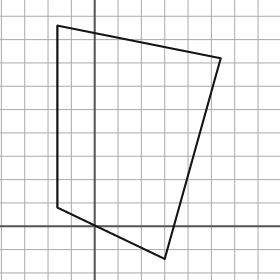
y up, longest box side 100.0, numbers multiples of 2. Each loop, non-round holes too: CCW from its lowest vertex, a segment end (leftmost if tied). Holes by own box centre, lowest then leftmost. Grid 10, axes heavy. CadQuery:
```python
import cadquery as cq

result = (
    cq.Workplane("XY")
    .moveTo(30.0, -14.0)
    .lineTo(54.0, 72.0)
    .lineTo(-16.0, 86.0)
    .lineTo(-16.0, 8.0)
    .close()
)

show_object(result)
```